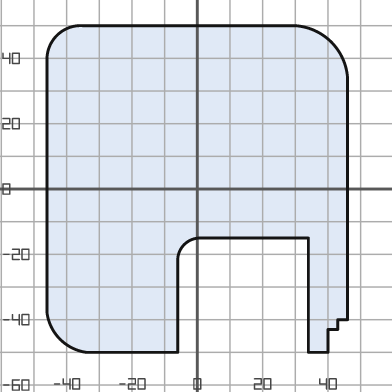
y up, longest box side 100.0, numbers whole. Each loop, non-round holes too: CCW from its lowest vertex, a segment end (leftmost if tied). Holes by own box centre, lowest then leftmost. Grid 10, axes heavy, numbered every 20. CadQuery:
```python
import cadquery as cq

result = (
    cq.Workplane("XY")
    .moveTo(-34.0, -50.0)
    .lineTo(-6.0, -50.0)
    .lineTo(-6.0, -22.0)
    .threePointArc((-4.0, -17.0), (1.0, -15.0))
    .lineTo(34.0, -15.0)
    .lineTo(34.0, -50.0)
    .lineTo(40.0, -50.0)
    .lineTo(40.0, -43.0)
    .lineTo(43.0, -43.0)
    .lineTo(43.0, -40.0)
    .lineTo(46.0, -40.0)
    .lineTo(46.0, 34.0)
    .threePointArc((41.0, 45.0), (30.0, 50.0))
    .lineTo(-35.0, 50.0)
    .threePointArc((-43.0, 47.0), (-46.0, 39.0))
    .lineTo(-46.0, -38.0)
    .threePointArc((-42.0, -46.0), (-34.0, -50.0))
    .close()
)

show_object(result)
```